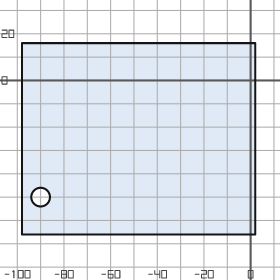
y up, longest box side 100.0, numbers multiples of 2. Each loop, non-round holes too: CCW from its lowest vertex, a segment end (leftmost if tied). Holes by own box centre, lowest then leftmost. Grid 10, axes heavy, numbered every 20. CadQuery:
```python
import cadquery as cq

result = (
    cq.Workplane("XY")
    .moveTo(-98.0, -66.0)
    .lineTo(2.0, -66.0)
    .lineTo(2.0, 16.0)
    .lineTo(-98.0, 16.0)
    .close()
    .moveTo(-90.0, -50.0)
    .circle(4.0)
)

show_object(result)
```